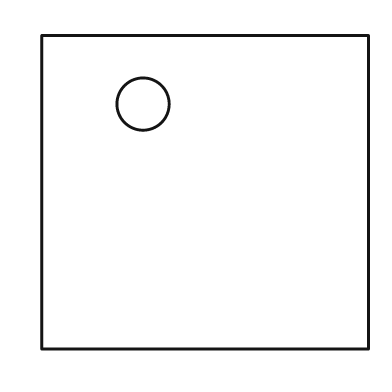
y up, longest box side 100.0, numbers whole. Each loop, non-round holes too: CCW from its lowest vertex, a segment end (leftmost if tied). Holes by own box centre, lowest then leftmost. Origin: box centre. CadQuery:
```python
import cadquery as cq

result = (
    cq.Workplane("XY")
    .moveTo(-50.0, -48.0)
    .lineTo(50.0, -48.0)
    .lineTo(50.0, 48.0)
    .lineTo(-50.0, 48.0)
    .close()
    .moveTo(-19.0, 27.0)
    .circle(8.0)
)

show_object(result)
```